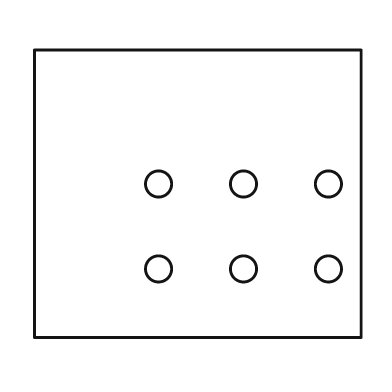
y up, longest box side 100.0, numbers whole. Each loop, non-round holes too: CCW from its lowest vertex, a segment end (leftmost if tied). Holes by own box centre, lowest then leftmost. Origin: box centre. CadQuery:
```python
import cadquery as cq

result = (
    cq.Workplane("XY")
    .moveTo(-50.0, -44.0)
    .lineTo(50.0, -44.0)
    .lineTo(50.0, 44.0)
    .lineTo(-50.0, 44.0)
    .close()
    .moveTo(-12.0, -23.0)
    .circle(4.0)
    .moveTo(14.0, -23.0)
    .circle(4.0)
    .moveTo(40.0, -23.0)
    .circle(4.0)
    .moveTo(-12.0, 3.0)
    .circle(4.0)
    .moveTo(14.0, 3.0)
    .circle(4.0)
    .moveTo(40.0, 3.0)
    .circle(4.0)
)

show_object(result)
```